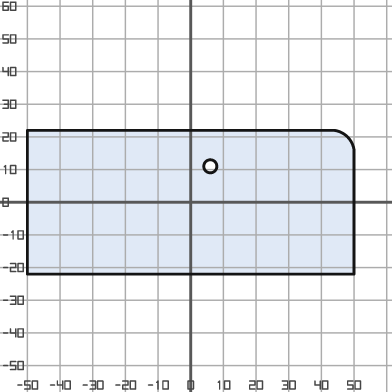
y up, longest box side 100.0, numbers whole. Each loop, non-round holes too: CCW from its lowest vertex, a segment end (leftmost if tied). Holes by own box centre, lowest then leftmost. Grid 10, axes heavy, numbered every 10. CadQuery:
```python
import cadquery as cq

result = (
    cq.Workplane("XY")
    .moveTo(-50.0, -22.0)
    .lineTo(50.0, -22.0)
    .lineTo(50.0, 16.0)
    .threePointArc((48.0, 20.0), (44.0, 22.0))
    .lineTo(-50.0, 22.0)
    .close()
    .moveTo(6.0, 11.0)
    .circle(2.0)
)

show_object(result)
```